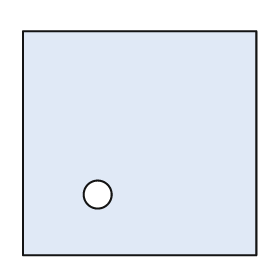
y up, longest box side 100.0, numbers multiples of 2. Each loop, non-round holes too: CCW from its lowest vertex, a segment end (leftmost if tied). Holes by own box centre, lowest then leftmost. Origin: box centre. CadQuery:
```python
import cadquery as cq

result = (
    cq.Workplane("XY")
    .moveTo(-50.0, -48.0)
    .lineTo(50.0, -48.0)
    .lineTo(50.0, 48.0)
    .lineTo(-50.0, 48.0)
    .close()
    .moveTo(-18.0, -22.0)
    .circle(6.0)
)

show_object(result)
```